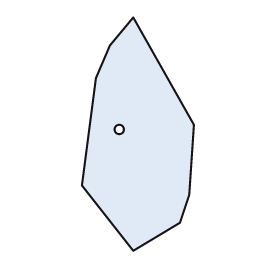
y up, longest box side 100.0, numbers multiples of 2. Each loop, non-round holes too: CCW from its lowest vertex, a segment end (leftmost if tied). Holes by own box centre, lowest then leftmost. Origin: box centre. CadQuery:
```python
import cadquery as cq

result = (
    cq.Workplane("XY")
    .moveTo(-2.0, -50.0)
    .lineTo(18.0, -38.0)
    .lineTo(22.0, -26.0)
    .lineTo(24.0, 4.0)
    .lineTo(-2.0, 50.0)
    .lineTo(-12.0, 38.0)
    .lineTo(-18.0, 24.0)
    .lineTo(-24.0, -22.0)
    .close()
    .moveTo(-8.0, 2.0)
    .circle(2.0)
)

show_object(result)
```